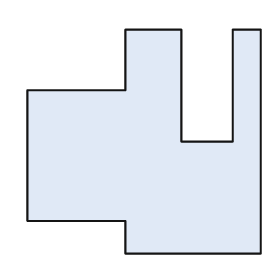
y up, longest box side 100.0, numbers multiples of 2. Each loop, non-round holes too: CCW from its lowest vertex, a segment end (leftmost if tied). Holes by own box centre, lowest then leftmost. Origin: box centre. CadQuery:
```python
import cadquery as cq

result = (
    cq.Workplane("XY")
    .moveTo(-8.0, -48.0)
    .lineTo(50.0, -48.0)
    .lineTo(50.0, 48.0)
    .lineTo(38.0, 48.0)
    .lineTo(38.0, 0.0)
    .lineTo(16.0, 0.0)
    .lineTo(16.0, 48.0)
    .lineTo(-8.0, 48.0)
    .lineTo(-8.0, 22.0)
    .lineTo(-50.0, 22.0)
    .lineTo(-50.0, -34.0)
    .lineTo(-8.0, -34.0)
    .close()
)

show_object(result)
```